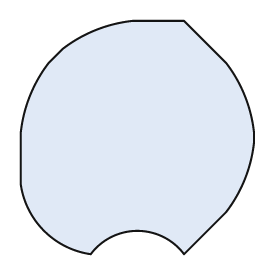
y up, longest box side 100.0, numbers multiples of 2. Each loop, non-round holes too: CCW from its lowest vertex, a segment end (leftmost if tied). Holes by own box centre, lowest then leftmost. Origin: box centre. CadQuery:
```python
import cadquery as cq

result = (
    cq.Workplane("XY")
    .moveTo(-20.0, -50.0)
    .threePointArc((0.0, -40.0), (20.0, -50.0))
    .lineTo(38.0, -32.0)
    .threePointArc((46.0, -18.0), (50.0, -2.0))
    .lineTo(50.0, 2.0)
    .threePointArc((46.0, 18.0), (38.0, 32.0))
    .lineTo(20.0, 50.0)
    .lineTo(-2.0, 50.0)
    .threePointArc((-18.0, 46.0), (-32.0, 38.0))
    .lineTo(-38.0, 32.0)
    .threePointArc((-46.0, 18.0), (-50.0, 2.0))
    .lineTo(-50.0, -20.0)
    .threePointArc((-40.0, -40.0), (-20.0, -50.0))
    .close()
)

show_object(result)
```